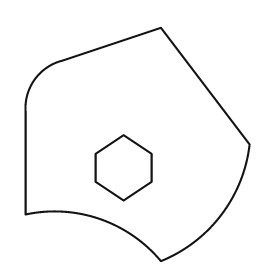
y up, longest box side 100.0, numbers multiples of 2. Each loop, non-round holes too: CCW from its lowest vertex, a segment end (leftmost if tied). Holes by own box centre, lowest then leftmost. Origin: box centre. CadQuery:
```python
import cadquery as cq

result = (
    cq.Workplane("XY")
    .moveTo(10.0, -50.0)
    .threePointArc((36.0, -30.0), (48.0, 0.0))
    .lineTo(10.0, 50.0)
    .lineTo(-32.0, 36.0)
    .threePointArc((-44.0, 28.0), (-48.0, 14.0))
    .lineTo(-48.0, -30.0)
    .threePointArc((-16.0, -32.0), (10.0, -50.0))
    .close()
    .moveTo(-6.0, -24.0)
    .lineTo(6.0, -16.0)
    .lineTo(6.0, -4.0)
    .lineTo(-6.0, 4.0)
    .lineTo(-18.0, -4.0)
    .lineTo(-18.0, -16.0)
    .close()
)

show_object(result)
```